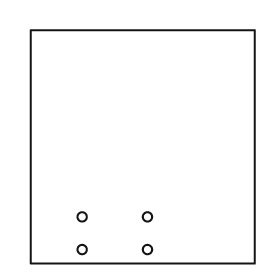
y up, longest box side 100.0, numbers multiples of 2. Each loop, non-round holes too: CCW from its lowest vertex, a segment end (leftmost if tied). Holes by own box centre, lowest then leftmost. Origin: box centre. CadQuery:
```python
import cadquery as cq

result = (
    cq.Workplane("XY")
    .moveTo(-48.0, -50.0)
    .lineTo(48.0, -50.0)
    .lineTo(48.0, 50.0)
    .lineTo(-48.0, 50.0)
    .close()
    .moveTo(-26.0, -44.0)
    .circle(2.0)
    .moveTo(2.0, -44.0)
    .circle(2.0)
    .moveTo(-26.0, -30.0)
    .circle(2.0)
    .moveTo(2.0, -30.0)
    .circle(2.0)
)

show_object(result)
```